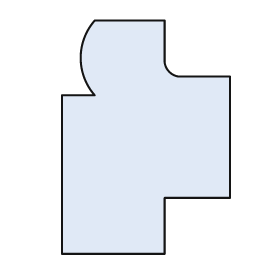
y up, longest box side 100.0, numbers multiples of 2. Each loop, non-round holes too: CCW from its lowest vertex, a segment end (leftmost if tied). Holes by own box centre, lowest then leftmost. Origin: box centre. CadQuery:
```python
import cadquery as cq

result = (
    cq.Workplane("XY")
    .moveTo(-36.0, -50.0)
    .lineTo(8.0, -50.0)
    .lineTo(8.0, -26.0)
    .lineTo(36.0, -26.0)
    .lineTo(36.0, 26.0)
    .lineTo(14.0, 26.0)
    .threePointArc((10.0, 28.0), (8.0, 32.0))
    .lineTo(8.0, 50.0)
    .lineTo(-22.0, 50.0)
    .threePointArc((-28.0, 34.0), (-22.0, 18.0))
    .lineTo(-36.0, 18.0)
    .close()
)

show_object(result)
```